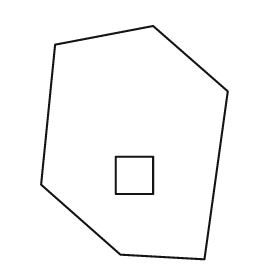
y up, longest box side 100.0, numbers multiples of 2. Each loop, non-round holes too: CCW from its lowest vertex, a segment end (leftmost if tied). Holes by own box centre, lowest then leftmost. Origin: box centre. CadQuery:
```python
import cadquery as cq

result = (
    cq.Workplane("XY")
    .moveTo(30.0, -50.0)
    .lineTo(40.0, 22.0)
    .lineTo(8.0, 50.0)
    .lineTo(-34.0, 42.0)
    .lineTo(-40.0, -18.0)
    .lineTo(-6.0, -48.0)
    .close()
    .moveTo(-8.0, -22.0)
    .lineTo(8.0, -22.0)
    .lineTo(8.0, -6.0)
    .lineTo(-8.0, -6.0)
    .close()
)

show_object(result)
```